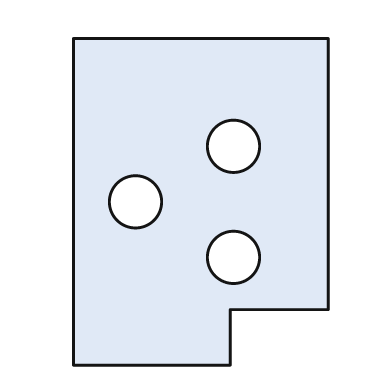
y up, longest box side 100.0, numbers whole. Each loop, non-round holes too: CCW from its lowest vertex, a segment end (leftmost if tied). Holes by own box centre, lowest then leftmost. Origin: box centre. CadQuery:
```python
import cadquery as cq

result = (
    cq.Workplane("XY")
    .moveTo(-39.0, -50.0)
    .lineTo(9.0, -50.0)
    .lineTo(9.0, -33.0)
    .lineTo(39.0, -33.0)
    .lineTo(39.0, 50.0)
    .lineTo(-39.0, 50.0)
    .close()
    .moveTo(10.0, -17.0)
    .circle(8.0)
    .moveTo(-20.0, 0.0)
    .circle(8.0)
    .moveTo(10.0, 17.0)
    .circle(8.0)
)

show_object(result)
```